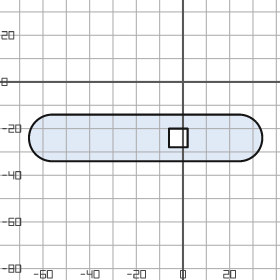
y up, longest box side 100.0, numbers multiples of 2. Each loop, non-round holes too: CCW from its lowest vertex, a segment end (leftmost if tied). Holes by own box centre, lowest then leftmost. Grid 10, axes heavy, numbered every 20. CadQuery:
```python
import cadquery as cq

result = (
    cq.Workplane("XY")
    .moveTo(-56.0, -34.0)
    .lineTo(24.0, -34.0)
    .threePointArc((34.0, -24.0), (24.0, -14.0))
    .lineTo(-56.0, -14.0)
    .threePointArc((-66.0, -24.0), (-56.0, -34.0))
    .close()
    .moveTo(-6.0, -28.0)
    .lineTo(2.0, -28.0)
    .lineTo(2.0, -20.0)
    .lineTo(-6.0, -20.0)
    .close()
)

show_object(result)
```